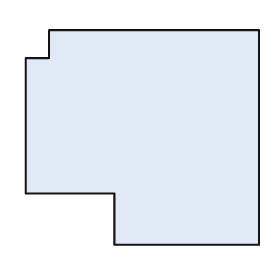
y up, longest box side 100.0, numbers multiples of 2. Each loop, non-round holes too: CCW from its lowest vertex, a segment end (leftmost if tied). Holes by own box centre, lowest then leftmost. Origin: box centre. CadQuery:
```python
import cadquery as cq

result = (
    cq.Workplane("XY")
    .moveTo(-12.0, -46.0)
    .lineTo(50.0, -46.0)
    .lineTo(50.0, 46.0)
    .lineTo(-40.0, 46.0)
    .lineTo(-40.0, 34.0)
    .lineTo(-50.0, 34.0)
    .lineTo(-50.0, -24.0)
    .lineTo(-12.0, -24.0)
    .close()
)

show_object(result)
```